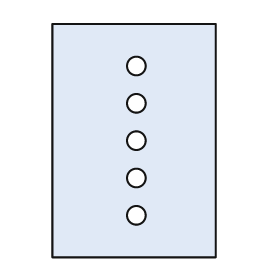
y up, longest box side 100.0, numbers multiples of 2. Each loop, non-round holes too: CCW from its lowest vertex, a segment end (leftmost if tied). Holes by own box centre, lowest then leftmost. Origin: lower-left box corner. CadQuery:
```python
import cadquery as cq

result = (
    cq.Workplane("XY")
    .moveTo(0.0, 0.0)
    .lineTo(70.0, 0.0)
    .lineTo(70.0, 100.0)
    .lineTo(0.0, 100.0)
    .close()
    .moveTo(36.0, 18.0)
    .circle(4.0)
    .moveTo(36.0, 34.0)
    .circle(4.0)
    .moveTo(36.0, 50.0)
    .circle(4.0)
    .moveTo(36.0, 66.0)
    .circle(4.0)
    .moveTo(36.0, 82.0)
    .circle(4.0)
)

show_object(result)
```